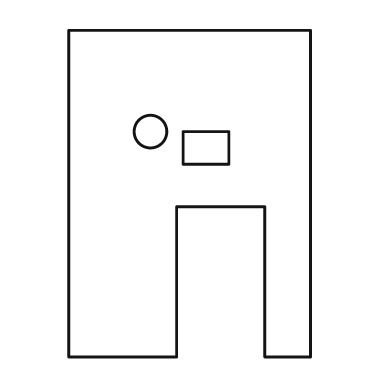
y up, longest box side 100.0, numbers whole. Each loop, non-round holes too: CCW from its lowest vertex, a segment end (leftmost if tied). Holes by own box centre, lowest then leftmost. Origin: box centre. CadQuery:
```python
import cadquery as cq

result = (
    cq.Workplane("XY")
    .moveTo(-37.0, -50.0)
    .lineTo(-4.0, -50.0)
    .lineTo(-4.0, -4.0)
    .lineTo(23.0, -4.0)
    .lineTo(23.0, -50.0)
    .lineTo(37.0, -50.0)
    .lineTo(37.0, 50.0)
    .lineTo(-37.0, 50.0)
    .close()
    .moveTo(-2.0, 9.0)
    .lineTo(12.0, 9.0)
    .lineTo(12.0, 19.0)
    .lineTo(-2.0, 19.0)
    .close()
    .moveTo(-12.0, 19.0)
    .circle(5.0)
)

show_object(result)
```